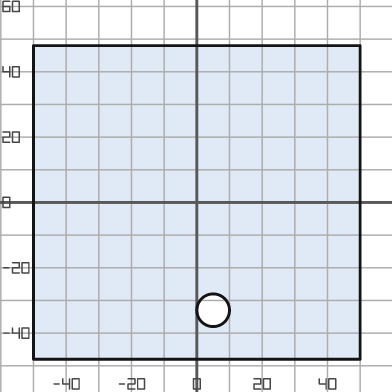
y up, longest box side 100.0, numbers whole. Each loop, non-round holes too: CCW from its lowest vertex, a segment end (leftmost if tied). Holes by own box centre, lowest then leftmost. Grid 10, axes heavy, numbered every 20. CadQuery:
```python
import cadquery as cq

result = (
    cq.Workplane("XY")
    .moveTo(-50.0, -48.0)
    .lineTo(50.0, -48.0)
    .lineTo(50.0, 48.0)
    .lineTo(-50.0, 48.0)
    .close()
    .moveTo(5.0, -33.0)
    .circle(5.0)
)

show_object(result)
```